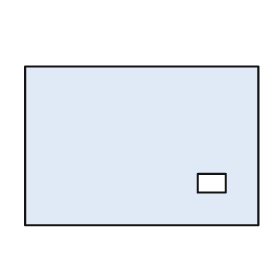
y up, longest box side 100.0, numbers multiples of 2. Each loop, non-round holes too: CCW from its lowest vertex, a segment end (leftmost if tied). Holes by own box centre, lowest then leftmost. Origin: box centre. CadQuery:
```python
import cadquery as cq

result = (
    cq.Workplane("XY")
    .moveTo(-50.0, -34.0)
    .lineTo(50.0, -34.0)
    .lineTo(50.0, 34.0)
    .lineTo(-50.0, 34.0)
    .close()
    .moveTo(24.0, -20.0)
    .lineTo(36.0, -20.0)
    .lineTo(36.0, -12.0)
    .lineTo(24.0, -12.0)
    .close()
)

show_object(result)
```